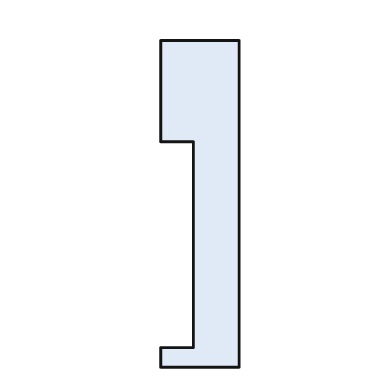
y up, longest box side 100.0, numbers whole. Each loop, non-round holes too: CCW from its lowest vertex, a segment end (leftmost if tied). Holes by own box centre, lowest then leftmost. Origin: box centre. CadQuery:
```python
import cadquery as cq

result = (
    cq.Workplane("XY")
    .moveTo(-12.0, -50.0)
    .lineTo(12.0, -50.0)
    .lineTo(12.0, 50.0)
    .lineTo(-12.0, 50.0)
    .lineTo(-12.0, 19.0)
    .lineTo(-2.0, 19.0)
    .lineTo(-2.0, -44.0)
    .lineTo(-12.0, -44.0)
    .close()
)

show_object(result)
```